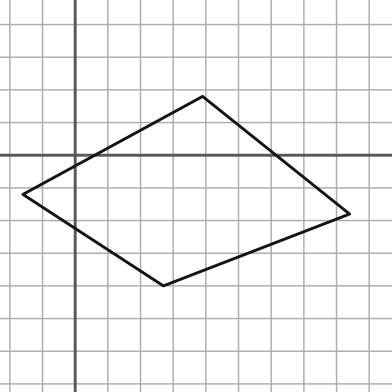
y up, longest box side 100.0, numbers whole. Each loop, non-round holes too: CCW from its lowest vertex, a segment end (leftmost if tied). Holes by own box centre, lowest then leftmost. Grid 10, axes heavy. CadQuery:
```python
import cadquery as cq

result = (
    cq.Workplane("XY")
    .moveTo(27.0, -40.0)
    .lineTo(84.0, -18.0)
    .lineTo(39.0, 18.0)
    .lineTo(-16.0, -12.0)
    .close()
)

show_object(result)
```